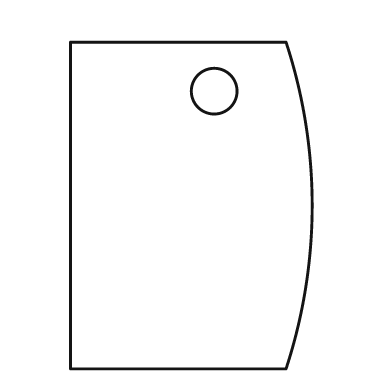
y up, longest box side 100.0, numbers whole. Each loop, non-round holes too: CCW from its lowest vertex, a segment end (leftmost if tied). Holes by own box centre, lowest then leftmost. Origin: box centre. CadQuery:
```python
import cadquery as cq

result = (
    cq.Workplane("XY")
    .moveTo(-37.0, -50.0)
    .lineTo(29.0, -50.0)
    .threePointArc((37.0, 0.0), (29.0, 50.0))
    .lineTo(-37.0, 50.0)
    .close()
    .moveTo(7.0, 35.0)
    .circle(7.0)
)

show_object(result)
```